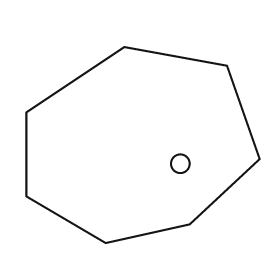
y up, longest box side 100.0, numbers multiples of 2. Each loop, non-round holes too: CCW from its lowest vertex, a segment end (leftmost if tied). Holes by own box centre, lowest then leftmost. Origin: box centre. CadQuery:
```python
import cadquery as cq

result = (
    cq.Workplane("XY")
    .moveTo(-16.0, -42.0)
    .lineTo(20.0, -34.0)
    .lineTo(50.0, -6.0)
    .lineTo(36.0, 34.0)
    .lineTo(-8.0, 42.0)
    .lineTo(-50.0, 14.0)
    .lineTo(-50.0, -22.0)
    .close()
    .moveTo(16.0, -8.0)
    .circle(4.0)
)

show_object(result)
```